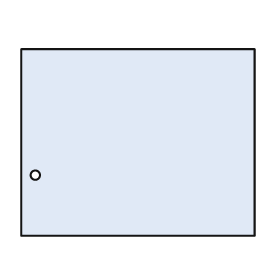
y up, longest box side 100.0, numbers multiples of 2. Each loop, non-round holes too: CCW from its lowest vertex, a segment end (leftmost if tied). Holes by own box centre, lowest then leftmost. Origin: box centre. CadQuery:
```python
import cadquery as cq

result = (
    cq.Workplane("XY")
    .moveTo(-50.0, -40.0)
    .lineTo(50.0, -40.0)
    .lineTo(50.0, 40.0)
    .lineTo(-50.0, 40.0)
    .close()
    .moveTo(-44.0, -14.0)
    .circle(2.0)
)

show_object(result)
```